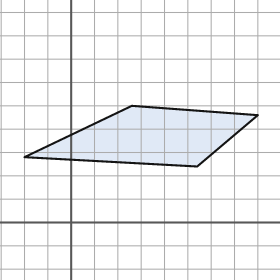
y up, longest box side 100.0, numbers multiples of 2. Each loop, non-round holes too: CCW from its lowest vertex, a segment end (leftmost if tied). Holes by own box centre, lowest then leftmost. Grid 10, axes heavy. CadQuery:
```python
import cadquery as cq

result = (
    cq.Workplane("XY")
    .moveTo(54.0, 24.0)
    .lineTo(80.0, 46.0)
    .lineTo(26.0, 50.0)
    .lineTo(-20.0, 28.0)
    .close()
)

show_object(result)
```